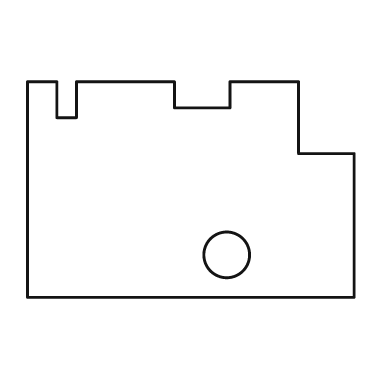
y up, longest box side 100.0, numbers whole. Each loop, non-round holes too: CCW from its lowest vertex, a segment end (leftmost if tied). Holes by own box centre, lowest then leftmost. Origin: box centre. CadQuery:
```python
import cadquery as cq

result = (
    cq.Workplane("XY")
    .moveTo(-50.0, -33.0)
    .lineTo(50.0, -33.0)
    .lineTo(50.0, 11.0)
    .lineTo(33.0, 11.0)
    .lineTo(33.0, 33.0)
    .lineTo(12.0, 33.0)
    .lineTo(12.0, 25.0)
    .lineTo(-5.0, 25.0)
    .lineTo(-5.0, 33.0)
    .lineTo(-35.0, 33.0)
    .lineTo(-35.0, 22.0)
    .lineTo(-41.0, 22.0)
    .lineTo(-41.0, 33.0)
    .lineTo(-50.0, 33.0)
    .close()
    .moveTo(11.0, -20.0)
    .circle(7.0)
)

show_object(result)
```